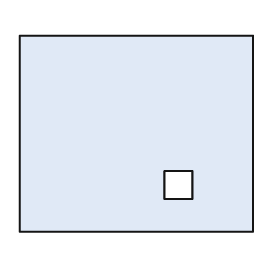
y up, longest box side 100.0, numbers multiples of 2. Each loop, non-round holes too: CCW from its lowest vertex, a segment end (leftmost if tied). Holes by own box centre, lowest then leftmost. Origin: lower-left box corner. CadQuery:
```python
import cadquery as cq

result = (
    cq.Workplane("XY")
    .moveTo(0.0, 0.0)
    .lineTo(100.0, 0.0)
    .lineTo(100.0, 84.0)
    .lineTo(0.0, 84.0)
    .close()
    .moveTo(62.0, 14.0)
    .lineTo(74.0, 14.0)
    .lineTo(74.0, 26.0)
    .lineTo(62.0, 26.0)
    .close()
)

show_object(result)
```